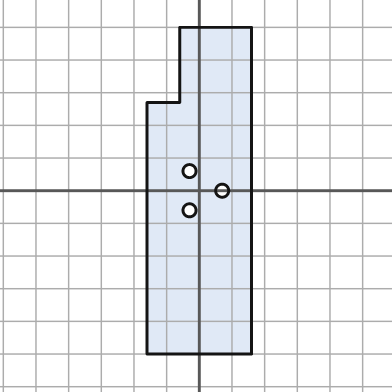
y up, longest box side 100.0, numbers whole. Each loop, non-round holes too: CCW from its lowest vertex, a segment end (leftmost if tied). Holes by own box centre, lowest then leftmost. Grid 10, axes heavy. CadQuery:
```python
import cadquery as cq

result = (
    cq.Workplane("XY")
    .moveTo(-16.0, -50.0)
    .lineTo(16.0, -50.0)
    .lineTo(16.0, 50.0)
    .lineTo(-6.0, 50.0)
    .lineTo(-6.0, 27.0)
    .lineTo(-16.0, 27.0)
    .close()
    .moveTo(-3.0, -6.0)
    .circle(2.0)
    .moveTo(7.0, 0.0)
    .circle(2.0)
    .moveTo(-3.0, 6.0)
    .circle(2.0)
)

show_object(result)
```